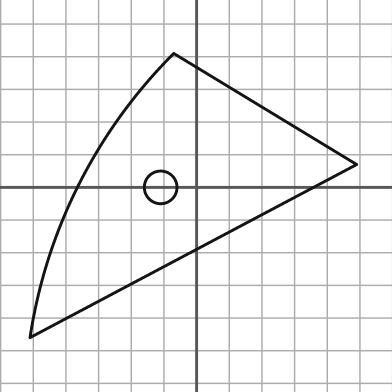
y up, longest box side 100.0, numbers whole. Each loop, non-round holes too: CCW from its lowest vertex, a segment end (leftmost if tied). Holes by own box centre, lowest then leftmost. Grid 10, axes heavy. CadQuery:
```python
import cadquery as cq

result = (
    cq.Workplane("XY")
    .moveTo(-51.0, -46.0)
    .lineTo(49.0, 7.0)
    .lineTo(-7.0, 41.0)
    .threePointArc((-36.0, 1.0), (-51.0, -46.0))
    .close()
    .moveTo(-11.0, 0.0)
    .circle(5.0)
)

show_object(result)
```